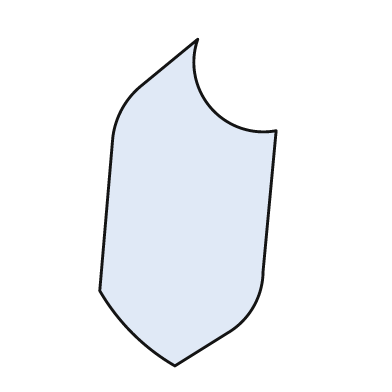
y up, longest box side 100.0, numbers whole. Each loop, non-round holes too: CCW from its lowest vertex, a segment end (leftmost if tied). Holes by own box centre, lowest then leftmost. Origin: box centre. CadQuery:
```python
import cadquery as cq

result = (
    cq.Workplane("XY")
    .moveTo(-4.0, -50.0)
    .lineTo(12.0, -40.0)
    .threePointArc((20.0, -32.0), (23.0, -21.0))
    .lineTo(27.0, 22.0)
    .threePointArc((7.0, 29.0), (3.0, 50.0))
    .lineTo(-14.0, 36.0)
    .threePointArc((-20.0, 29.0), (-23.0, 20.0))
    .lineTo(-27.0, -27.0)
    .threePointArc((-17.0, -40.0), (-4.0, -50.0))
    .close()
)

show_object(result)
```